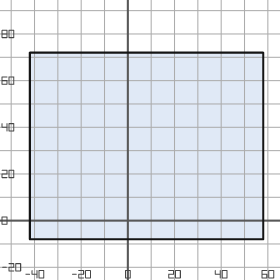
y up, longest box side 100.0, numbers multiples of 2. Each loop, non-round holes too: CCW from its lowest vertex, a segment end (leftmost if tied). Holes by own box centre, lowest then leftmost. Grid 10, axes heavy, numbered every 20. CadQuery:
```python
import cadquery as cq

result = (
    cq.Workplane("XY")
    .moveTo(-42.0, -8.0)
    .lineTo(58.0, -8.0)
    .lineTo(58.0, 72.0)
    .lineTo(-42.0, 72.0)
    .close()
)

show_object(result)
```